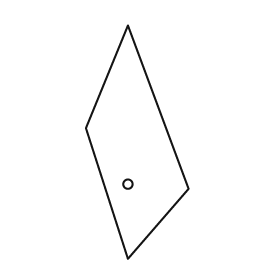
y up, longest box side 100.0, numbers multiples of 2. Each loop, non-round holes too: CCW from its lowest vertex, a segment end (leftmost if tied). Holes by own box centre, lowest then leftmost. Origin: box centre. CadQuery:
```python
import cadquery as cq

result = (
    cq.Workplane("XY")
    .moveTo(-4.0, -50.0)
    .lineTo(22.0, -20.0)
    .lineTo(-4.0, 50.0)
    .lineTo(-22.0, 6.0)
    .close()
    .moveTo(-4.0, -18.0)
    .circle(2.0)
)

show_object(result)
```